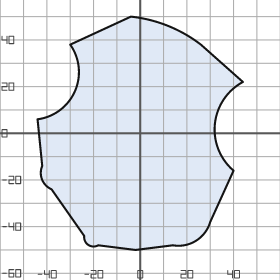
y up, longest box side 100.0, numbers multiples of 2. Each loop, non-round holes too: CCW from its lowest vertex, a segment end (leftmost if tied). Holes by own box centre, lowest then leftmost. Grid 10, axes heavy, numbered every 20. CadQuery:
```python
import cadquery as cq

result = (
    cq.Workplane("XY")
    .moveTo(-2.0, -50.0)
    .lineTo(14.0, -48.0)
    .threePointArc((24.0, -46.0), (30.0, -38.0))
    .lineTo(40.0, -16.0)
    .threePointArc((32.0, 4.0), (44.0, 22.0))
    .lineTo(26.0, 38.0)
    .threePointArc((12.0, 46.0), (-4.0, 50.0))
    .lineTo(-30.0, 38.0)
    .threePointArc((-28.0, 18.0), (-44.0, 6.0))
    .lineTo(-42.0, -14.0)
    .threePointArc((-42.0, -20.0), (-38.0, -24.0))
    .lineTo(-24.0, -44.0)
    .threePointArc((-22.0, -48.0), (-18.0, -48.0))
    .close()
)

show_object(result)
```